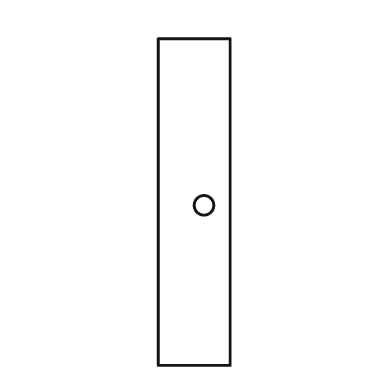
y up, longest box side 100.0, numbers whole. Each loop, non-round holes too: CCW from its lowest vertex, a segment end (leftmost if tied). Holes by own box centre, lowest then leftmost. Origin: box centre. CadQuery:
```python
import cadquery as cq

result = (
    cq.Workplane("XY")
    .moveTo(-11.0, -50.0)
    .lineTo(11.0, -50.0)
    .lineTo(11.0, 50.0)
    .lineTo(-11.0, 50.0)
    .close()
    .moveTo(3.0, -1.0)
    .circle(3.0)
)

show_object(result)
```